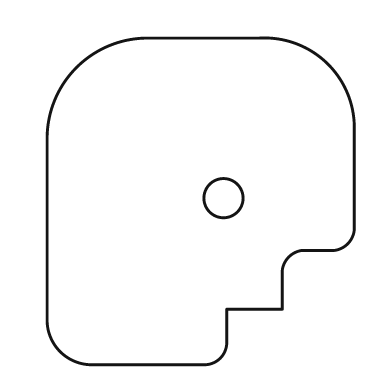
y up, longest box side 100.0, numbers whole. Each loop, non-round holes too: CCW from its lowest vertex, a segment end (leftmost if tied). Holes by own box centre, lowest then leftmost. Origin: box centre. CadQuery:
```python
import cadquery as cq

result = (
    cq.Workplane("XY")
    .moveTo(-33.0, -50.0)
    .lineTo(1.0, -50.0)
    .threePointArc((6.0, -48.0), (8.0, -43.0))
    .lineTo(8.0, -33.0)
    .lineTo(25.0, -33.0)
    .lineTo(25.0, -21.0)
    .threePointArc((27.0, -17.0), (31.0, -15.0))
    .lineTo(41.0, -15.0)
    .threePointArc((45.0, -13.0), (47.0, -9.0))
    .lineTo(47.0, 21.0)
    .threePointArc((39.0, 42.0), (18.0, 50.0))
    .lineTo(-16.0, 50.0)
    .threePointArc((-38.0, 41.0), (-47.0, 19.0))
    .lineTo(-47.0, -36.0)
    .threePointArc((-43.0, -46.0), (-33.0, -50.0))
    .close()
    .moveTo(7.0, 1.0)
    .circle(6.0)
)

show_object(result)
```